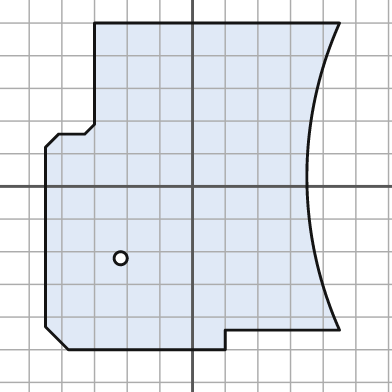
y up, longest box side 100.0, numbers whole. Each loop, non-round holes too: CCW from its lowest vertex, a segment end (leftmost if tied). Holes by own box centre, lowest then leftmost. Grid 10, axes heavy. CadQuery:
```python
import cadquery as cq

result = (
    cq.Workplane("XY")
    .moveTo(-38.0, -50.0)
    .lineTo(10.0, -50.0)
    .lineTo(10.0, -44.0)
    .lineTo(45.0, -44.0)
    .threePointArc((35.0, 3.0), (45.0, 50.0))
    .lineTo(-30.0, 50.0)
    .lineTo(-30.0, 19.0)
    .lineTo(-33.0, 16.0)
    .lineTo(-41.0, 16.0)
    .lineTo(-45.0, 12.0)
    .lineTo(-45.0, -43.0)
    .close()
    .moveTo(-22.0, -22.0)
    .circle(2.0)
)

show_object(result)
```